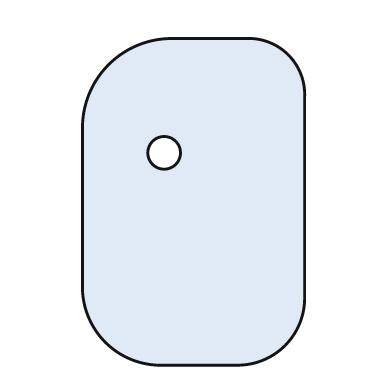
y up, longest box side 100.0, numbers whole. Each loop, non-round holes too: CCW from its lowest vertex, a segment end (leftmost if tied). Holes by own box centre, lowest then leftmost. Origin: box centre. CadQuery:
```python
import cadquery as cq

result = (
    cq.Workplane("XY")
    .moveTo(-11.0, -50.0)
    .lineTo(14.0, -50.0)
    .threePointArc((28.0, -44.0), (34.0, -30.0))
    .lineTo(34.0, 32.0)
    .threePointArc((29.0, 45.0), (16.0, 50.0))
    .lineTo(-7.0, 50.0)
    .threePointArc((-26.0, 42.0), (-34.0, 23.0))
    .lineTo(-34.0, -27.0)
    .threePointArc((-27.0, -43.0), (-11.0, -50.0))
    .close()
    .moveTo(-9.0, 15.0)
    .circle(5.0)
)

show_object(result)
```